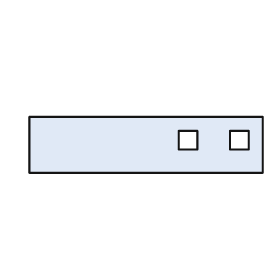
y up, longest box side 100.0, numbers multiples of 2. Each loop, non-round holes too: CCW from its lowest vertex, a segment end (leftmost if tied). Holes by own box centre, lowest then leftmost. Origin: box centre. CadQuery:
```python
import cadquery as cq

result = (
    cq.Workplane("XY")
    .moveTo(-50.0, -12.0)
    .lineTo(50.0, -12.0)
    .lineTo(50.0, 12.0)
    .lineTo(-50.0, 12.0)
    .close()
    .moveTo(14.0, -2.0)
    .lineTo(22.0, -2.0)
    .lineTo(22.0, 6.0)
    .lineTo(14.0, 6.0)
    .close()
    .moveTo(36.0, -2.0)
    .lineTo(44.0, -2.0)
    .lineTo(44.0, 6.0)
    .lineTo(36.0, 6.0)
    .close()
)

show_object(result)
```